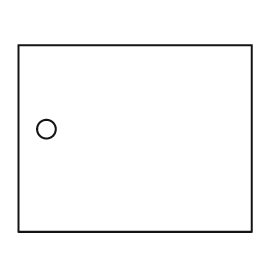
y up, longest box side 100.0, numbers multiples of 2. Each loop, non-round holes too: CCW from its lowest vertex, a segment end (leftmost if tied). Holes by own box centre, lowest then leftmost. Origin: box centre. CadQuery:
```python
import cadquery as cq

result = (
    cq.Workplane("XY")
    .moveTo(-50.0, -40.0)
    .lineTo(50.0, -40.0)
    .lineTo(50.0, 40.0)
    .lineTo(-50.0, 40.0)
    .close()
    .moveTo(-38.0, 4.0)
    .circle(4.0)
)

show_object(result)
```